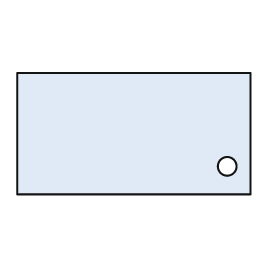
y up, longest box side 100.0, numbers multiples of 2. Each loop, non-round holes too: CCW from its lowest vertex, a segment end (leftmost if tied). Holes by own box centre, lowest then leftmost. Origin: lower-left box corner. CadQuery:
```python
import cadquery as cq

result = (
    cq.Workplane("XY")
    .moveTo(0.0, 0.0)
    .lineTo(100.0, 0.0)
    .lineTo(100.0, 52.0)
    .lineTo(0.0, 52.0)
    .close()
    .moveTo(90.0, 12.0)
    .circle(4.0)
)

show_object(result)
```